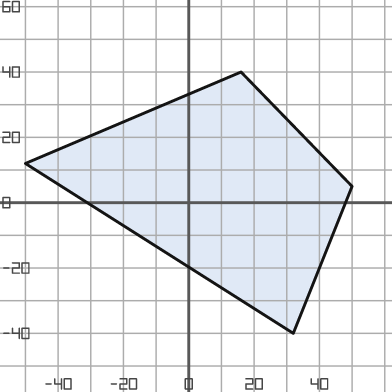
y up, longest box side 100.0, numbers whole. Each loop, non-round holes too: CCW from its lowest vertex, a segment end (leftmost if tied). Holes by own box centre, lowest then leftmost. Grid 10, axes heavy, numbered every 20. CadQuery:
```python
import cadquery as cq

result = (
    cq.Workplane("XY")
    .moveTo(32.0, -40.0)
    .lineTo(50.0, 5.0)
    .lineTo(16.0, 40.0)
    .lineTo(-50.0, 12.0)
    .close()
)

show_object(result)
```